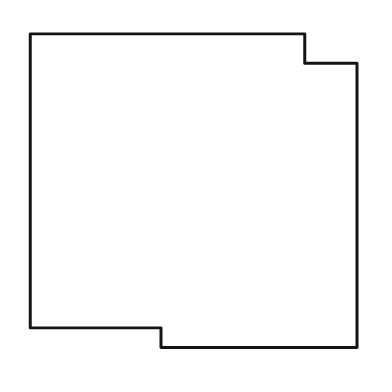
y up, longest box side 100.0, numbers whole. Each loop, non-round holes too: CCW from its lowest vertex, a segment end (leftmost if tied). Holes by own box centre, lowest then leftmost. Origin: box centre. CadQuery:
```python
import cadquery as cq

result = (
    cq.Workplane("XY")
    .moveTo(-10.0, -48.0)
    .lineTo(50.0, -48.0)
    .lineTo(50.0, 39.0)
    .lineTo(34.0, 39.0)
    .lineTo(34.0, 48.0)
    .lineTo(-50.0, 48.0)
    .lineTo(-50.0, -42.0)
    .lineTo(-10.0, -42.0)
    .close()
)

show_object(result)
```